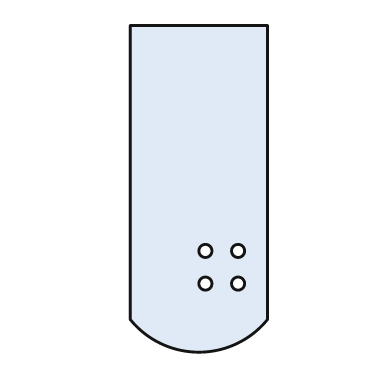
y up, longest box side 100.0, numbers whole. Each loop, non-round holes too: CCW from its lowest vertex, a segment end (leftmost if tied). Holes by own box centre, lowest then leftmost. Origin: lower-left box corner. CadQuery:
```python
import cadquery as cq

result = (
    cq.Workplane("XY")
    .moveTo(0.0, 10.0)
    .threePointArc((21.0, 0.0), (42.0, 10.0))
    .lineTo(42.0, 100.0)
    .lineTo(0.0, 100.0)
    .close()
    .moveTo(23.0, 21.0)
    .circle(2.0)
    .moveTo(33.0, 21.0)
    .circle(2.0)
    .moveTo(23.0, 31.0)
    .circle(2.0)
    .moveTo(33.0, 31.0)
    .circle(2.0)
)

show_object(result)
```